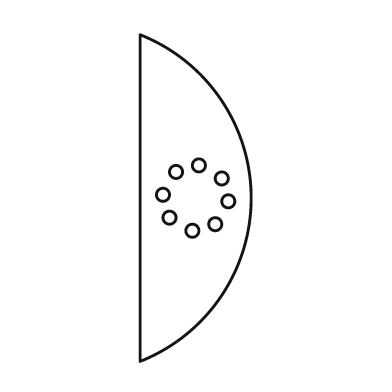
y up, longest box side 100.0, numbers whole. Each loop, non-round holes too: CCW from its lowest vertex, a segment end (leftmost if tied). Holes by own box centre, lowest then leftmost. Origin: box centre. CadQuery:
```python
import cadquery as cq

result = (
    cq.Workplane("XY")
    .moveTo(-17.0, -50.0)
    .threePointArc((17.0, 0.0), (-17.0, 50.0))
    .close()
    .moveTo(-1.0, -10.0)
    .circle(2.0)
    .moveTo(6.0, -8.0)
    .circle(2.0)
    .moveTo(-8.0, -6.0)
    .circle(2.0)
    .moveTo(10.0, -1.0)
    .circle(2.0)
    .moveTo(-10.0, 1.0)
    .circle(2.0)
    .moveTo(8.0, 6.0)
    .circle(2.0)
    .moveTo(-6.0, 8.0)
    .circle(2.0)
    .moveTo(1.0, 10.0)
    .circle(2.0)
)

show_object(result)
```